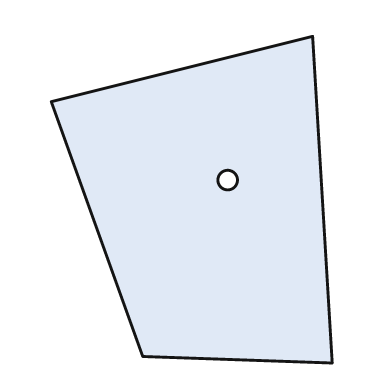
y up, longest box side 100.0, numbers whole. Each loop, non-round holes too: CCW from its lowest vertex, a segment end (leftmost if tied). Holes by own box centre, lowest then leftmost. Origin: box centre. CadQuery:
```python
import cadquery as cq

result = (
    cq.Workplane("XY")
    .moveTo(43.0, -50.0)
    .lineTo(37.0, 50.0)
    .lineTo(-43.0, 30.0)
    .lineTo(-15.0, -48.0)
    .close()
    .moveTo(11.0, 6.0)
    .circle(3.0)
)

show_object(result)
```